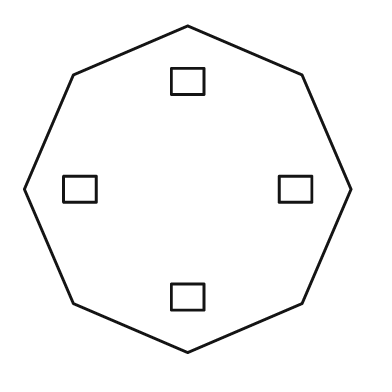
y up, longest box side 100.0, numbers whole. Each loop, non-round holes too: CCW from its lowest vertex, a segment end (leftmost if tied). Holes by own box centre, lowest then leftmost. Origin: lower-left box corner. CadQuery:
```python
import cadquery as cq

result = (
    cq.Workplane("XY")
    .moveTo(50.0, 0.0)
    .lineTo(85.0, 15.0)
    .lineTo(100.0, 50.0)
    .lineTo(85.0, 85.0)
    .lineTo(50.0, 100.0)
    .lineTo(15.0, 85.0)
    .lineTo(0.0, 50.0)
    .lineTo(15.0, 15.0)
    .close()
    .moveTo(45.0, 13.0)
    .lineTo(55.0, 13.0)
    .lineTo(55.0, 21.0)
    .lineTo(45.0, 21.0)
    .close()
    .moveTo(12.0, 46.0)
    .lineTo(22.0, 46.0)
    .lineTo(22.0, 54.0)
    .lineTo(12.0, 54.0)
    .close()
    .moveTo(78.0, 46.0)
    .lineTo(88.0, 46.0)
    .lineTo(88.0, 54.0)
    .lineTo(78.0, 54.0)
    .close()
    .moveTo(45.0, 79.0)
    .lineTo(55.0, 79.0)
    .lineTo(55.0, 87.0)
    .lineTo(45.0, 87.0)
    .close()
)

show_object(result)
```